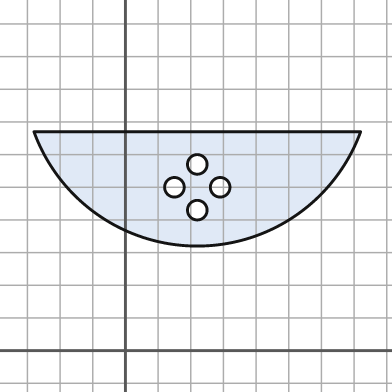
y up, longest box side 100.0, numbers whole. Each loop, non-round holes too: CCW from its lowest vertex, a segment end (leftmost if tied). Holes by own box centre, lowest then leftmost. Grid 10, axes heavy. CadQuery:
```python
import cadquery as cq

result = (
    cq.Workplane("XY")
    .moveTo(-28.0, 67.0)
    .threePointArc((22.0, 32.0), (72.0, 67.0))
    .close()
    .moveTo(22.0, 43.0)
    .circle(3.0)
    .moveTo(15.0, 50.0)
    .circle(3.0)
    .moveTo(29.0, 50.0)
    .circle(3.0)
    .moveTo(22.0, 57.0)
    .circle(3.0)
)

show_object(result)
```